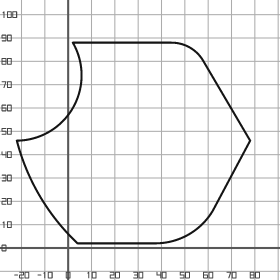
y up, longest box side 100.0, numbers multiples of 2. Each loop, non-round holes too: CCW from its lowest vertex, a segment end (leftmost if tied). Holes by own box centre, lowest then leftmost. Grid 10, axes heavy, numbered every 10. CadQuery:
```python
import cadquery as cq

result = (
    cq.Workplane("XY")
    .moveTo(4.0, 2.0)
    .lineTo(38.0, 2.0)
    .threePointArc((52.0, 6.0), (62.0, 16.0))
    .lineTo(78.0, 46.0)
    .lineTo(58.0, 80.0)
    .threePointArc((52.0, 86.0), (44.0, 88.0))
    .lineTo(2.0, 88.0)
    .threePointArc((2.0, 60.0), (-22.0, 46.0))
    .threePointArc((-12.0, 22.0), (4.0, 2.0))
    .close()
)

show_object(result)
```